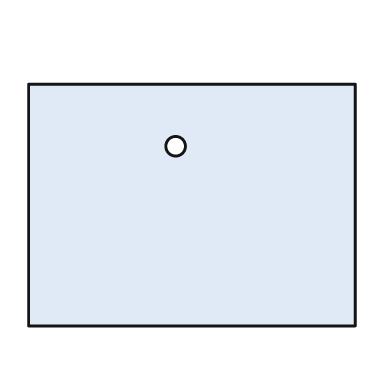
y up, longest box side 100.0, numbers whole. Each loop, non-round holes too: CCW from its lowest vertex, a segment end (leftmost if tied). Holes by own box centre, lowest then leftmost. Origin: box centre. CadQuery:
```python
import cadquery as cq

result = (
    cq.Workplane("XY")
    .moveTo(-50.0, -37.0)
    .lineTo(50.0, -37.0)
    .lineTo(50.0, 37.0)
    .lineTo(-50.0, 37.0)
    .close()
    .moveTo(-5.0, 18.0)
    .circle(3.0)
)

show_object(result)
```